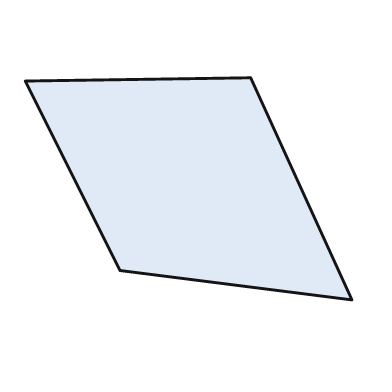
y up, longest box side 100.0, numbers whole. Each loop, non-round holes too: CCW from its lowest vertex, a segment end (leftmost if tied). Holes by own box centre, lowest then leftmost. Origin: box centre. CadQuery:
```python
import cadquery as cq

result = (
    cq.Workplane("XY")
    .moveTo(50.0, -34.0)
    .lineTo(19.0, 34.0)
    .lineTo(-50.0, 33.0)
    .lineTo(-21.0, -25.0)
    .close()
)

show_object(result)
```